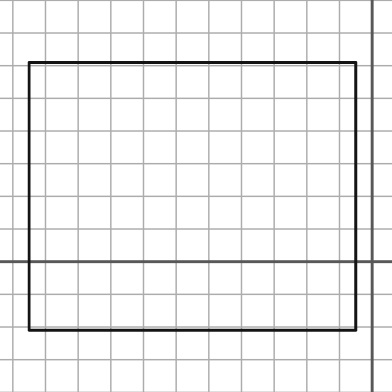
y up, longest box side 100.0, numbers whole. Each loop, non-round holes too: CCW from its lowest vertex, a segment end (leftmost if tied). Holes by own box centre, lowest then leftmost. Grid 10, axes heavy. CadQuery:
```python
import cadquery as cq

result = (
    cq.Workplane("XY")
    .moveTo(-105.0, -21.0)
    .lineTo(-5.0, -21.0)
    .lineTo(-5.0, 61.0)
    .lineTo(-105.0, 61.0)
    .close()
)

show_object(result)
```